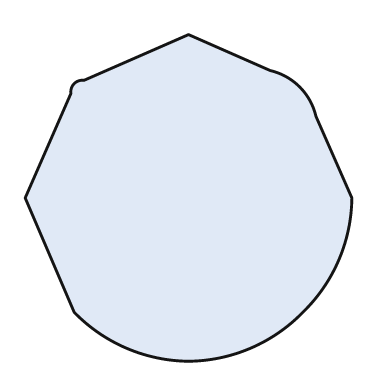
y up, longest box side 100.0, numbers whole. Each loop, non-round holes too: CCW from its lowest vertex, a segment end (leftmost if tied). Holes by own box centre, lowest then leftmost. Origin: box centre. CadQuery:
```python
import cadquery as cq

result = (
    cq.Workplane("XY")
    .moveTo(0.0, -50.0)
    .threePointArc((19.0, -46.0), (35.0, -35.0))
    .threePointArc((46.0, -19.0), (50.0, 0.0))
    .lineTo(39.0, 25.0)
    .threePointArc((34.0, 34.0), (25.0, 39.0))
    .lineTo(0.0, 50.0)
    .lineTo(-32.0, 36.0)
    .threePointArc((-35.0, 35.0), (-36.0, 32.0))
    .lineTo(-50.0, 0.0)
    .lineTo(-35.0, -35.0)
    .threePointArc((-19.0, -46.0), (0.0, -50.0))
    .close()
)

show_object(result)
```